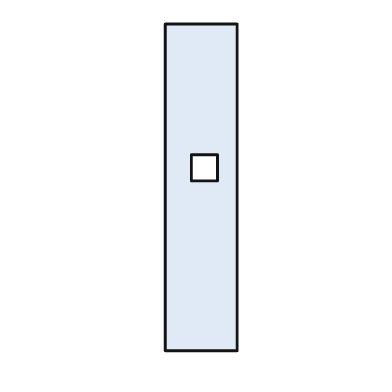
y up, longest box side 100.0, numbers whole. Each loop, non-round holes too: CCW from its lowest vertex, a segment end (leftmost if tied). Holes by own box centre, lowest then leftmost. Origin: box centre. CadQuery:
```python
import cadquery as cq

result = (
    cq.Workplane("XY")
    .moveTo(-11.0, -50.0)
    .lineTo(11.0, -50.0)
    .lineTo(11.0, 50.0)
    .lineTo(-11.0, 50.0)
    .close()
    .moveTo(-3.0, 2.0)
    .lineTo(5.0, 2.0)
    .lineTo(5.0, 10.0)
    .lineTo(-3.0, 10.0)
    .close()
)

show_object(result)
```